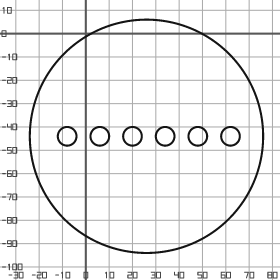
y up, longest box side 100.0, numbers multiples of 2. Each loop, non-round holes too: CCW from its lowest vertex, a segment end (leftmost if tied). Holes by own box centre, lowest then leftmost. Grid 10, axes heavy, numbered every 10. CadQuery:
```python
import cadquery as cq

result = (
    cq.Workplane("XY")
    .moveTo(26.0, -44.0)
    .circle(50.0)
    .moveTo(-8.0, -44.0)
    .circle(4.0)
    .moveTo(6.0, -44.0)
    .circle(4.0)
    .moveTo(20.0, -44.0)
    .circle(4.0)
    .moveTo(34.0, -44.0)
    .circle(4.0)
    .moveTo(48.0, -44.0)
    .circle(4.0)
    .moveTo(62.0, -44.0)
    .circle(4.0)
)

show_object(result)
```